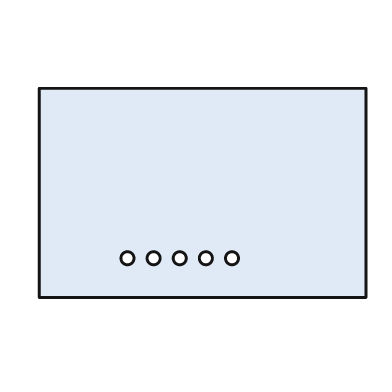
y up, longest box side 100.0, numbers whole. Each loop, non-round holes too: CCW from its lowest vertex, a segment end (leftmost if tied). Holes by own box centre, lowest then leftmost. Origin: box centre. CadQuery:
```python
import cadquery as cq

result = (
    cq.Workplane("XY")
    .moveTo(-50.0, -32.0)
    .lineTo(50.0, -32.0)
    .lineTo(50.0, 32.0)
    .lineTo(-50.0, 32.0)
    .close()
    .moveTo(-23.0, -20.0)
    .circle(2.0)
    .moveTo(-15.0, -20.0)
    .circle(2.0)
    .moveTo(-7.0, -20.0)
    .circle(2.0)
    .moveTo(1.0, -20.0)
    .circle(2.0)
    .moveTo(9.0, -20.0)
    .circle(2.0)
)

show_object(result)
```